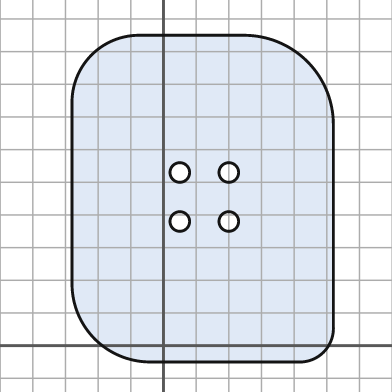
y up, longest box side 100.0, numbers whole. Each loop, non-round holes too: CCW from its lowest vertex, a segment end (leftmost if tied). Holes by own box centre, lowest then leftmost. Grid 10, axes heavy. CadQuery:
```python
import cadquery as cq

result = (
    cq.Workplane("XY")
    .moveTo(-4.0, -5.0)
    .lineTo(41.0, -5.0)
    .threePointArc((49.0, -2.0), (52.0, 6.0))
    .lineTo(52.0, 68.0)
    .threePointArc((44.0, 87.0), (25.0, 95.0))
    .lineTo(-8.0, 95.0)
    .threePointArc((-22.0, 89.0), (-28.0, 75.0))
    .lineTo(-28.0, 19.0)
    .threePointArc((-21.0, 2.0), (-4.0, -5.0))
    .close()
    .moveTo(5.0, 38.0)
    .circle(3.0)
    .moveTo(20.0, 38.0)
    .circle(3.0)
    .moveTo(5.0, 53.0)
    .circle(3.0)
    .moveTo(20.0, 53.0)
    .circle(3.0)
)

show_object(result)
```